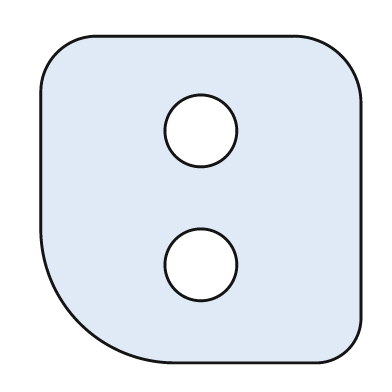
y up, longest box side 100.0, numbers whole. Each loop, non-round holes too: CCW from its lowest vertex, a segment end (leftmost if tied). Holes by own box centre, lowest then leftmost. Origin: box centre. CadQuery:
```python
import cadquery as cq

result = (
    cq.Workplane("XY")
    .moveTo(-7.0, -50.0)
    .lineTo(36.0, -50.0)
    .threePointArc((45.0, -46.0), (49.0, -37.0))
    .lineTo(49.0, 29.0)
    .threePointArc((43.0, 44.0), (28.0, 50.0))
    .lineTo(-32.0, 50.0)
    .threePointArc((-44.0, 45.0), (-49.0, 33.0))
    .lineTo(-49.0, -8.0)
    .threePointArc((-37.0, -38.0), (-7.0, -50.0))
    .close()
    .moveTo(0.0, -20.0)
    .circle(11.0)
    .moveTo(0.0, 21.0)
    .circle(11.0)
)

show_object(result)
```